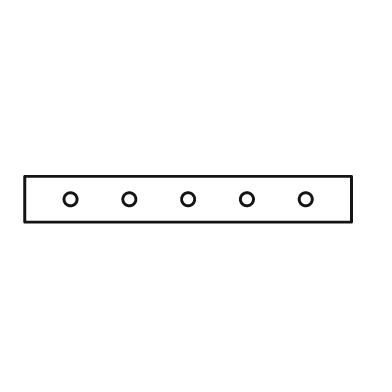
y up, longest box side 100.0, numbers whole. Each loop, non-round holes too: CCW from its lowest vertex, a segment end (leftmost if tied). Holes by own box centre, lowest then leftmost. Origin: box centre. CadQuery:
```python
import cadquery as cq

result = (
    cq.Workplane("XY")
    .moveTo(-50.0, -7.0)
    .lineTo(50.0, -7.0)
    .lineTo(50.0, 7.0)
    .lineTo(-50.0, 7.0)
    .close()
    .moveTo(-36.0, 0.0)
    .circle(2.0)
    .moveTo(-18.0, 0.0)
    .circle(2.0)
    .moveTo(0.0, 0.0)
    .circle(2.0)
    .moveTo(18.0, 0.0)
    .circle(2.0)
    .moveTo(36.0, 0.0)
    .circle(2.0)
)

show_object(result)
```